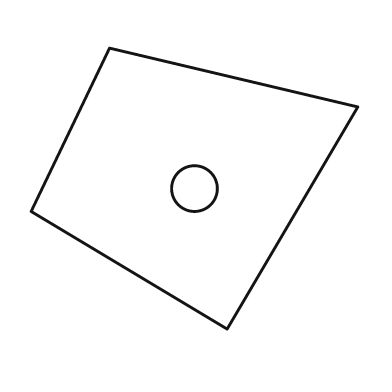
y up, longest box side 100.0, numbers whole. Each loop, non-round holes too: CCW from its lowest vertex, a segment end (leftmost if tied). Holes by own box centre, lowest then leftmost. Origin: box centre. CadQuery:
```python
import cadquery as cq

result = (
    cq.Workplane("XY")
    .moveTo(10.0, -43.0)
    .lineTo(50.0, 25.0)
    .lineTo(-26.0, 43.0)
    .lineTo(-50.0, -7.0)
    .close()
    .moveTo(0.0, 0.0)
    .circle(7.0)
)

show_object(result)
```